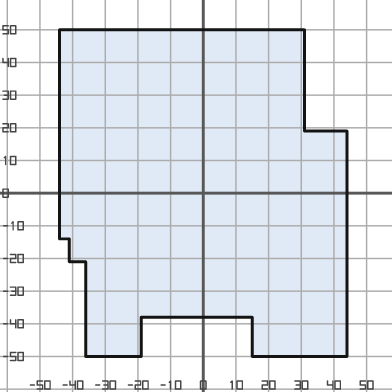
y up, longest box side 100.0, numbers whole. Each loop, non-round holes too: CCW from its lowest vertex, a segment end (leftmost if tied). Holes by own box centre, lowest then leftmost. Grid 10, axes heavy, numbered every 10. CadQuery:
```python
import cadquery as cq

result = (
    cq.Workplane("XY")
    .moveTo(-36.0, -50.0)
    .lineTo(-19.0, -50.0)
    .lineTo(-19.0, -38.0)
    .lineTo(15.0, -38.0)
    .lineTo(15.0, -50.0)
    .lineTo(44.0, -50.0)
    .lineTo(44.0, 19.0)
    .lineTo(31.0, 19.0)
    .lineTo(31.0, 50.0)
    .lineTo(-44.0, 50.0)
    .lineTo(-44.0, -14.0)
    .lineTo(-41.0, -14.0)
    .lineTo(-41.0, -21.0)
    .lineTo(-36.0, -21.0)
    .close()
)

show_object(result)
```